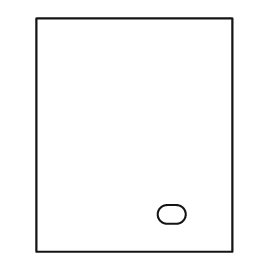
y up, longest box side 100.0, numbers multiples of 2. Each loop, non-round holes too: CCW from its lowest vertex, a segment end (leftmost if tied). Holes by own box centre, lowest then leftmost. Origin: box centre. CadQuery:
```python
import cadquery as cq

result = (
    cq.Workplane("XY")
    .moveTo(-42.0, -50.0)
    .lineTo(42.0, -50.0)
    .lineTo(42.0, 50.0)
    .lineTo(-42.0, 50.0)
    .close()
    .moveTo(14.0, -38.0)
    .lineTo(18.0, -38.0)
    .threePointArc((22.0, -34.0), (18.0, -30.0))
    .lineTo(14.0, -30.0)
    .threePointArc((10.0, -34.0), (14.0, -38.0))
    .close()
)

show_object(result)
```